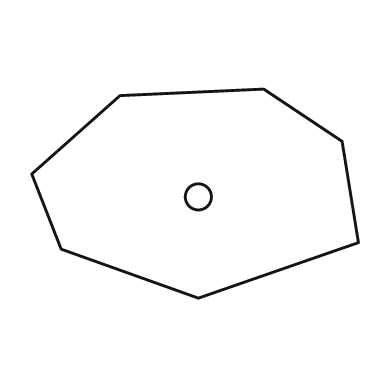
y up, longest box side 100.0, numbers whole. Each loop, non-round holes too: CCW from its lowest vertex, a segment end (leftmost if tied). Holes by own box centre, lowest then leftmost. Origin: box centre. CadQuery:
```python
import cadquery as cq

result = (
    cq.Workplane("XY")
    .moveTo(1.0, -32.0)
    .lineTo(50.0, -15.0)
    .lineTo(45.0, 16.0)
    .lineTo(21.0, 32.0)
    .lineTo(-23.0, 30.0)
    .lineTo(-50.0, 6.0)
    .lineTo(-41.0, -17.0)
    .close()
    .moveTo(1.0, -1.0)
    .circle(4.0)
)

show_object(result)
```